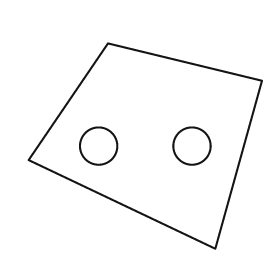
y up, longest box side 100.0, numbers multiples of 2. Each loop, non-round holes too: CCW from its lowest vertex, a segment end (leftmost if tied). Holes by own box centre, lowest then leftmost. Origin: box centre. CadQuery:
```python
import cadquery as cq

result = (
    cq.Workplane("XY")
    .moveTo(30.0, -44.0)
    .lineTo(50.0, 28.0)
    .lineTo(-16.0, 44.0)
    .lineTo(-50.0, -6.0)
    .close()
    .moveTo(-20.0, 0.0)
    .circle(8.0)
    .moveTo(20.0, 0.0)
    .circle(8.0)
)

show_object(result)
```